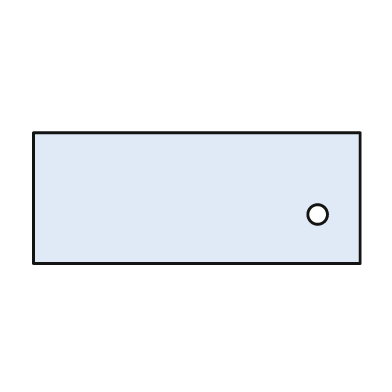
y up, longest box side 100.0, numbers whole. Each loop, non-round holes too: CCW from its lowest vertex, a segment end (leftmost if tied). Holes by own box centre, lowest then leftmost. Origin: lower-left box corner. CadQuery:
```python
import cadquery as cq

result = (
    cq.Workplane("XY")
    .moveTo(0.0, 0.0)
    .lineTo(100.0, 0.0)
    .lineTo(100.0, 40.0)
    .lineTo(0.0, 40.0)
    .close()
    .moveTo(87.0, 15.0)
    .circle(3.0)
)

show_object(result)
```